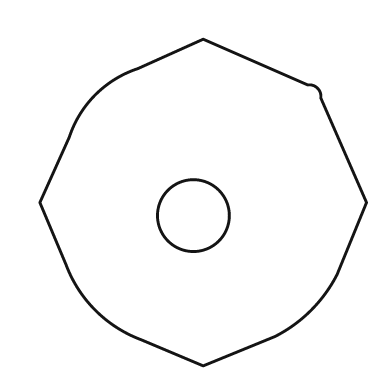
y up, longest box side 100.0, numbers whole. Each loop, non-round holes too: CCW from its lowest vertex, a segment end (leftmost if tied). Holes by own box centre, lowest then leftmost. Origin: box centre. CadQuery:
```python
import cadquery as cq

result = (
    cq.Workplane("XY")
    .moveTo(0.0, -50.0)
    .lineTo(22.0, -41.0)
    .threePointArc((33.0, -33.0), (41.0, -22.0))
    .lineTo(50.0, 0.0)
    .lineTo(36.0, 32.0)
    .threePointArc((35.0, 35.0), (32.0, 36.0))
    .lineTo(0.0, 50.0)
    .lineTo(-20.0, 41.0)
    .threePointArc((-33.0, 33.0), (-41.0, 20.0))
    .lineTo(-50.0, 0.0)
    .lineTo(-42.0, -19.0)
    .threePointArc((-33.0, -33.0), (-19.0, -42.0))
    .close()
    .moveTo(-3.0, -4.0)
    .circle(11.0)
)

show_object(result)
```